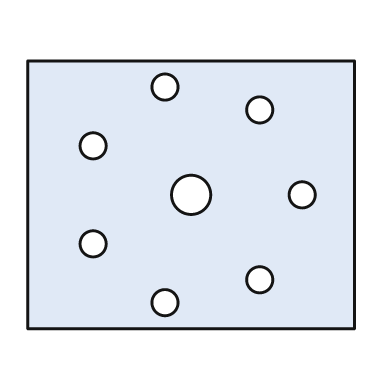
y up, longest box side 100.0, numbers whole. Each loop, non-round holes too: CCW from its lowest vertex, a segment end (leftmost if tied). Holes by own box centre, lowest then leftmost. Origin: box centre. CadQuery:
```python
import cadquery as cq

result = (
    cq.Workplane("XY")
    .moveTo(-50.0, -41.0)
    .lineTo(50.0, -41.0)
    .lineTo(50.0, 41.0)
    .lineTo(-50.0, 41.0)
    .close()
    .moveTo(-8.0, -33.0)
    .circle(4.0)
    .moveTo(21.0, -26.0)
    .circle(4.0)
    .moveTo(-30.0, -15.0)
    .circle(4.0)
    .moveTo(0.0, 0.0)
    .circle(6.0)
    .moveTo(34.0, 0.0)
    .circle(4.0)
    .moveTo(-30.0, 15.0)
    .circle(4.0)
    .moveTo(21.0, 26.0)
    .circle(4.0)
    .moveTo(-8.0, 33.0)
    .circle(4.0)
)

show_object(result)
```